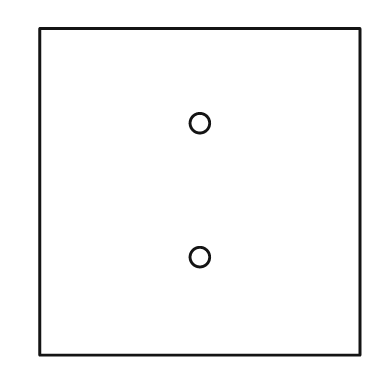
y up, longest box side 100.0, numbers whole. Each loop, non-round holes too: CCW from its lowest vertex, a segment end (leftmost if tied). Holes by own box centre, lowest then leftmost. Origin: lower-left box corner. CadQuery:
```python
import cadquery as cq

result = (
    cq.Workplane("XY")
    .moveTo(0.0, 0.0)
    .lineTo(98.0, 0.0)
    .lineTo(98.0, 100.0)
    .lineTo(0.0, 100.0)
    .close()
    .moveTo(49.0, 30.0)
    .circle(3.0)
    .moveTo(49.0, 71.0)
    .circle(3.0)
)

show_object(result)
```